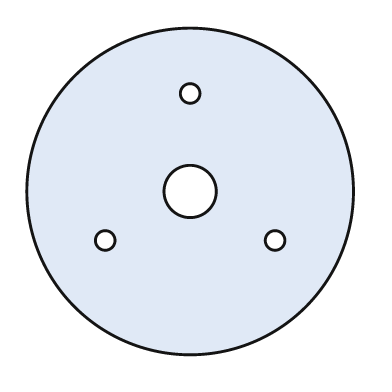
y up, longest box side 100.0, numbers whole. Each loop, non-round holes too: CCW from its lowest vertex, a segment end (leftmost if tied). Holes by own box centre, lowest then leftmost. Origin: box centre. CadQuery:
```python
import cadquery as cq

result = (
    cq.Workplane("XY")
    .moveTo(0.0, 0.0)
    .circle(50.0)
    .moveTo(-26.0, -15.0)
    .circle(3.0)
    .moveTo(26.0, -15.0)
    .circle(3.0)
    .moveTo(0.0, 0.0)
    .circle(8.0)
    .moveTo(0.0, 30.0)
    .circle(3.0)
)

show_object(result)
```